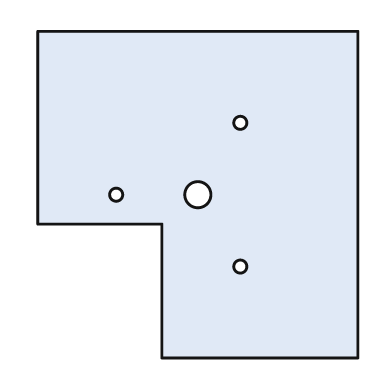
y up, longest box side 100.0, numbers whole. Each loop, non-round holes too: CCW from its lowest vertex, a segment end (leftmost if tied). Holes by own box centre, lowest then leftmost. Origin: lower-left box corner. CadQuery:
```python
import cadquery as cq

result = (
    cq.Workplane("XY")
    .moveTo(38.0, 0.0)
    .lineTo(98.0, 0.0)
    .lineTo(98.0, 100.0)
    .lineTo(0.0, 100.0)
    .lineTo(0.0, 41.0)
    .lineTo(38.0, 41.0)
    .close()
    .moveTo(62.0, 28.0)
    .circle(2.0)
    .moveTo(24.0, 50.0)
    .circle(2.0)
    .moveTo(49.0, 50.0)
    .circle(4.0)
    .moveTo(62.0, 72.0)
    .circle(2.0)
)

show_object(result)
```